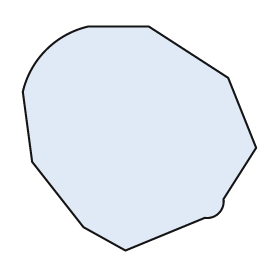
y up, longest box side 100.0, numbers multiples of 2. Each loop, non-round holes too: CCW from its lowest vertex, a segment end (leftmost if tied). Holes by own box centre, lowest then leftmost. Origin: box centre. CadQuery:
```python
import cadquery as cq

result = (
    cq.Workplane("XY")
    .moveTo(-6.0, -48.0)
    .lineTo(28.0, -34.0)
    .threePointArc((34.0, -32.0), (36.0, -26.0))
    .lineTo(50.0, -4.0)
    .lineTo(38.0, 26.0)
    .lineTo(4.0, 48.0)
    .lineTo(-22.0, 48.0)
    .threePointArc((-40.0, 38.0), (-50.0, 20.0))
    .lineTo(-46.0, -10.0)
    .lineTo(-24.0, -38.0)
    .close()
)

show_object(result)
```